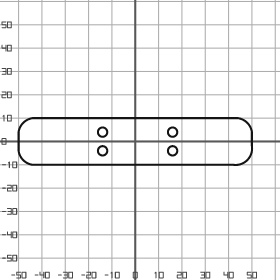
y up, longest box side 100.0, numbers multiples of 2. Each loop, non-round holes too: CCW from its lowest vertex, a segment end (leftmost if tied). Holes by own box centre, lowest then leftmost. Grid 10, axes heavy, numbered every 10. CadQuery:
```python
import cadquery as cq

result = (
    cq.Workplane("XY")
    .moveTo(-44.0, -10.0)
    .lineTo(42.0, -10.0)
    .threePointArc((48.0, -8.0), (50.0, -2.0))
    .lineTo(50.0, 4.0)
    .threePointArc((48.0, 8.0), (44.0, 10.0))
    .lineTo(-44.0, 10.0)
    .threePointArc((-48.0, 8.0), (-50.0, 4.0))
    .lineTo(-50.0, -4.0)
    .threePointArc((-48.0, -8.0), (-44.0, -10.0))
    .close()
    .moveTo(-14.0, -4.0)
    .circle(2.0)
    .moveTo(16.0, -4.0)
    .circle(2.0)
    .moveTo(-14.0, 4.0)
    .circle(2.0)
    .moveTo(16.0, 4.0)
    .circle(2.0)
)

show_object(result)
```